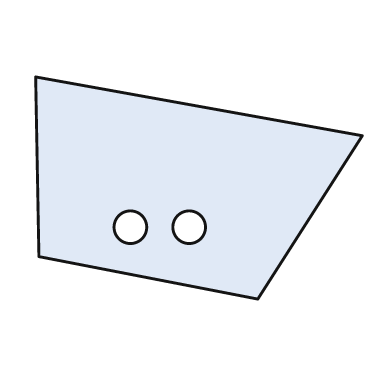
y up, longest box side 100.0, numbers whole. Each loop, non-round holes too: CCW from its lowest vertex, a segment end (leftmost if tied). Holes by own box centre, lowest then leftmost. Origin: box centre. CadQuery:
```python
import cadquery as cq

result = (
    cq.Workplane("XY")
    .moveTo(18.0, -34.0)
    .lineTo(50.0, 16.0)
    .lineTo(-50.0, 34.0)
    .lineTo(-49.0, -21.0)
    .close()
    .moveTo(-21.0, -12.0)
    .circle(5.0)
    .moveTo(-3.0, -12.0)
    .circle(5.0)
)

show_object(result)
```